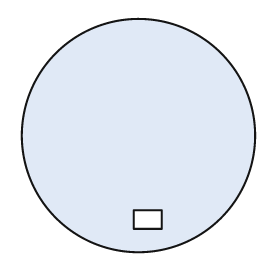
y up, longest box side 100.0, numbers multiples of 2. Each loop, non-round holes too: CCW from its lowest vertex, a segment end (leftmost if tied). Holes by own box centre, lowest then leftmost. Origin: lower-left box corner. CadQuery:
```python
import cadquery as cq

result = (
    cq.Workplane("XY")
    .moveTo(50.0, 50.0)
    .circle(50.0)
    .moveTo(48.0, 10.0)
    .lineTo(60.0, 10.0)
    .lineTo(60.0, 18.0)
    .lineTo(48.0, 18.0)
    .close()
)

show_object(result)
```